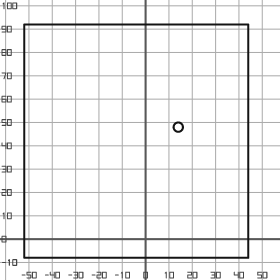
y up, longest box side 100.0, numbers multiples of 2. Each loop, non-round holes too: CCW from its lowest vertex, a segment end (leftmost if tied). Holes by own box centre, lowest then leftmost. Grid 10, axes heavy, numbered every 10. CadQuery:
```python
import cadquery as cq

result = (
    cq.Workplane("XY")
    .moveTo(-52.0, -8.0)
    .lineTo(44.0, -8.0)
    .lineTo(44.0, 92.0)
    .lineTo(-52.0, 92.0)
    .close()
    .moveTo(14.0, 48.0)
    .circle(2.0)
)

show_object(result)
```